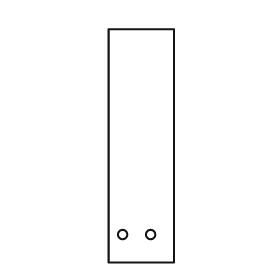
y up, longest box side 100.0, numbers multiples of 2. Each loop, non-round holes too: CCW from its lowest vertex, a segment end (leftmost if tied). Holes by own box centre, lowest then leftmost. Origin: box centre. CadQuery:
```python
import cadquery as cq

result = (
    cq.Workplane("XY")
    .moveTo(-14.0, -50.0)
    .lineTo(14.0, -50.0)
    .lineTo(14.0, 50.0)
    .lineTo(-14.0, 50.0)
    .close()
    .moveTo(-8.0, -38.0)
    .circle(2.0)
    .moveTo(4.0, -38.0)
    .circle(2.0)
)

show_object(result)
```